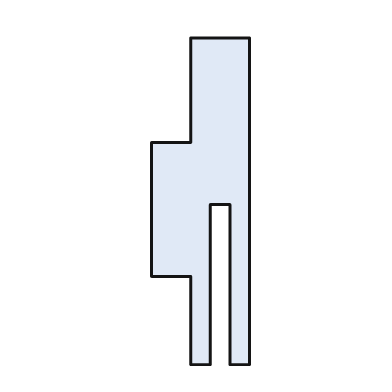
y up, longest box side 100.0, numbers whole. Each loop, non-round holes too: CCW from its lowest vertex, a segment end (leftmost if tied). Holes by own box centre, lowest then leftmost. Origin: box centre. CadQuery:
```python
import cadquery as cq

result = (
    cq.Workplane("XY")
    .moveTo(-3.0, -50.0)
    .lineTo(3.0, -50.0)
    .lineTo(3.0, -1.0)
    .lineTo(9.0, -1.0)
    .lineTo(9.0, -50.0)
    .lineTo(15.0, -50.0)
    .lineTo(15.0, 50.0)
    .lineTo(-3.0, 50.0)
    .lineTo(-3.0, 18.0)
    .lineTo(-15.0, 18.0)
    .lineTo(-15.0, -23.0)
    .lineTo(-3.0, -23.0)
    .close()
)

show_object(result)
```